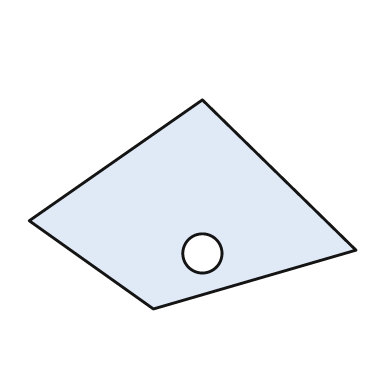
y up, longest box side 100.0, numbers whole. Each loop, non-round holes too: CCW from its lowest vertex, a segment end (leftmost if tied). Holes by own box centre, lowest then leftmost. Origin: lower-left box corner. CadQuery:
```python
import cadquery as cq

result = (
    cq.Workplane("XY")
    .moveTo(38.0, 0.0)
    .lineTo(100.0, 18.0)
    .lineTo(53.0, 64.0)
    .lineTo(0.0, 27.0)
    .close()
    .moveTo(53.0, 17.0)
    .circle(6.0)
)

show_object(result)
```